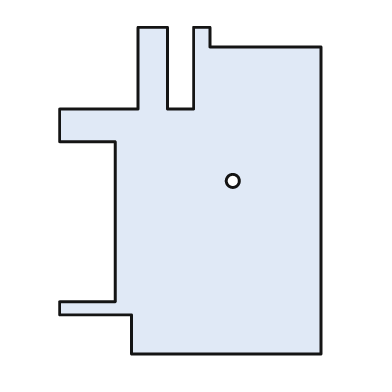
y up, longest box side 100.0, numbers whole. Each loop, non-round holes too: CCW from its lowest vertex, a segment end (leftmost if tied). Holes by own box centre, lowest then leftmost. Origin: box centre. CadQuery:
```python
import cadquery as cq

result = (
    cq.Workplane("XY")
    .moveTo(-18.0, -50.0)
    .lineTo(40.0, -50.0)
    .lineTo(40.0, 44.0)
    .lineTo(6.0, 44.0)
    .lineTo(6.0, 50.0)
    .lineTo(1.0, 50.0)
    .lineTo(1.0, 25.0)
    .lineTo(-7.0, 25.0)
    .lineTo(-7.0, 50.0)
    .lineTo(-16.0, 50.0)
    .lineTo(-16.0, 25.0)
    .lineTo(-40.0, 25.0)
    .lineTo(-40.0, 15.0)
    .lineTo(-23.0, 15.0)
    .lineTo(-23.0, -34.0)
    .lineTo(-40.0, -34.0)
    .lineTo(-40.0, -38.0)
    .lineTo(-18.0, -38.0)
    .close()
    .moveTo(13.0, 3.0)
    .circle(2.0)
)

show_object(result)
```